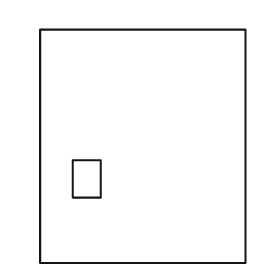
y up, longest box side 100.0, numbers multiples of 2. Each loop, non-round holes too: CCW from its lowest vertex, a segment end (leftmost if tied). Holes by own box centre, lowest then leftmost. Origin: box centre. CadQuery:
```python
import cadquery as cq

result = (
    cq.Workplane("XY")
    .moveTo(-44.0, -50.0)
    .lineTo(44.0, -50.0)
    .lineTo(44.0, 50.0)
    .lineTo(-44.0, 50.0)
    .close()
    .moveTo(-30.0, -22.0)
    .lineTo(-18.0, -22.0)
    .lineTo(-18.0, -6.0)
    .lineTo(-30.0, -6.0)
    .close()
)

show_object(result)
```